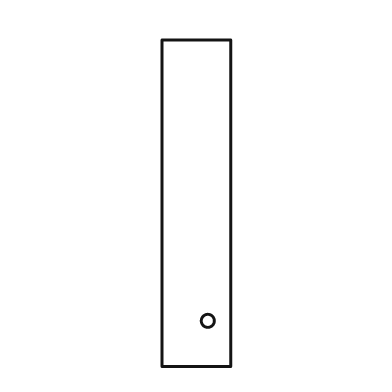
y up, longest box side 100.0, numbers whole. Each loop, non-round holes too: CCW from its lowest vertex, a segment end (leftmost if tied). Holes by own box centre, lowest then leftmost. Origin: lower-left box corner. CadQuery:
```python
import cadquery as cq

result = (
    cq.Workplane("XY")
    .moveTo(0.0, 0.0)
    .lineTo(21.0, 0.0)
    .lineTo(21.0, 100.0)
    .lineTo(0.0, 100.0)
    .close()
    .moveTo(14.0, 14.0)
    .circle(2.0)
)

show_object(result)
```